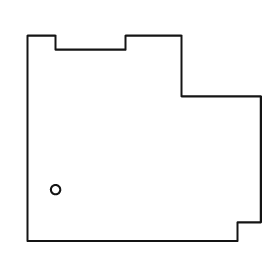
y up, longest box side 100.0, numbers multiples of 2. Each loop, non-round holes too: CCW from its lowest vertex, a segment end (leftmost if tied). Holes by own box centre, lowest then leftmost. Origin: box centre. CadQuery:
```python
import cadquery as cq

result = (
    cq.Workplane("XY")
    .moveTo(-50.0, -44.0)
    .lineTo(40.0, -44.0)
    .lineTo(40.0, -36.0)
    .lineTo(50.0, -36.0)
    .lineTo(50.0, 18.0)
    .lineTo(16.0, 18.0)
    .lineTo(16.0, 44.0)
    .lineTo(-8.0, 44.0)
    .lineTo(-8.0, 38.0)
    .lineTo(-38.0, 38.0)
    .lineTo(-38.0, 44.0)
    .lineTo(-50.0, 44.0)
    .close()
    .moveTo(-38.0, -22.0)
    .circle(2.0)
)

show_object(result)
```